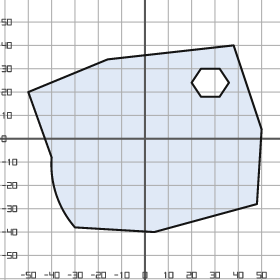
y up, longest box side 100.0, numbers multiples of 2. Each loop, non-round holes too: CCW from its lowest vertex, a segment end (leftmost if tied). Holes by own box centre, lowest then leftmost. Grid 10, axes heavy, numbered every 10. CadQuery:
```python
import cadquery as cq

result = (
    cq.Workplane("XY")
    .moveTo(4.0, -40.0)
    .lineTo(48.0, -28.0)
    .lineTo(50.0, 4.0)
    .lineTo(38.0, 40.0)
    .lineTo(-16.0, 34.0)
    .lineTo(-50.0, 20.0)
    .lineTo(-40.0, -8.0)
    .threePointArc((-38.0, -24.0), (-30.0, -38.0))
    .close()
    .moveTo(24.0, 18.0)
    .lineTo(32.0, 18.0)
    .lineTo(36.0, 24.0)
    .lineTo(32.0, 30.0)
    .lineTo(24.0, 30.0)
    .lineTo(20.0, 24.0)
    .close()
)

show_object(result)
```